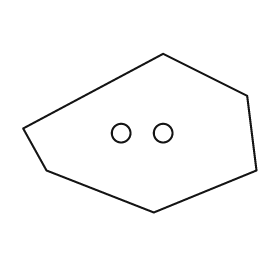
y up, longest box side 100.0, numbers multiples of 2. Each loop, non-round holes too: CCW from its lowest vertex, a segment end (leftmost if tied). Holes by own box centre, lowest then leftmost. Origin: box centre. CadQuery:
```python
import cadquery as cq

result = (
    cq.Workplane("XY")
    .moveTo(6.0, -34.0)
    .lineTo(50.0, -16.0)
    .lineTo(46.0, 16.0)
    .lineTo(10.0, 34.0)
    .lineTo(-50.0, 2.0)
    .lineTo(-40.0, -16.0)
    .close()
    .moveTo(-8.0, 0.0)
    .circle(4.0)
    .moveTo(10.0, 0.0)
    .circle(4.0)
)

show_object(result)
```